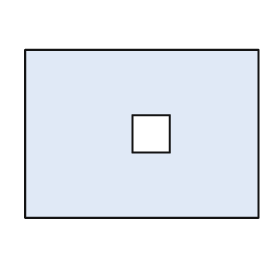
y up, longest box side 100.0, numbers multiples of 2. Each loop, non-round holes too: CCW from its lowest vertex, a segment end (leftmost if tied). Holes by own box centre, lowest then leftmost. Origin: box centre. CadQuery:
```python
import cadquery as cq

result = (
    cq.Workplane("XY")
    .moveTo(-50.0, -36.0)
    .lineTo(50.0, -36.0)
    .lineTo(50.0, 36.0)
    .lineTo(-50.0, 36.0)
    .close()
    .moveTo(-4.0, -8.0)
    .lineTo(12.0, -8.0)
    .lineTo(12.0, 8.0)
    .lineTo(-4.0, 8.0)
    .close()
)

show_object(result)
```